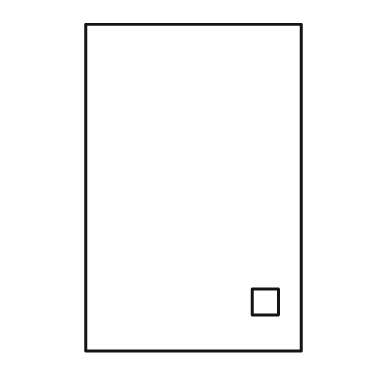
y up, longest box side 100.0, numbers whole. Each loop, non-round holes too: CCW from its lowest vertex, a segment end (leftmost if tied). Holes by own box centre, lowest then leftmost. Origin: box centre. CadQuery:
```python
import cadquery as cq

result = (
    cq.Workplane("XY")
    .moveTo(-33.0, -50.0)
    .lineTo(33.0, -50.0)
    .lineTo(33.0, 50.0)
    .lineTo(-33.0, 50.0)
    .close()
    .moveTo(18.0, -39.0)
    .lineTo(26.0, -39.0)
    .lineTo(26.0, -31.0)
    .lineTo(18.0, -31.0)
    .close()
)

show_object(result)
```